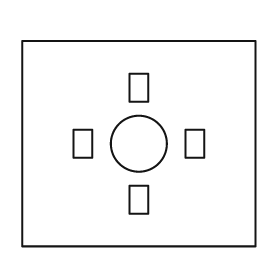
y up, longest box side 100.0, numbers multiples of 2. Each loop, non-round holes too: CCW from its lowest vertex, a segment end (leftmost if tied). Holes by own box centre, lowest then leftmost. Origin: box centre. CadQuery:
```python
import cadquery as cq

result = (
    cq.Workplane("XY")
    .moveTo(-50.0, -44.0)
    .lineTo(50.0, -44.0)
    .lineTo(50.0, 44.0)
    .lineTo(-50.0, 44.0)
    .close()
    .moveTo(-4.0, -30.0)
    .lineTo(4.0, -30.0)
    .lineTo(4.0, -18.0)
    .lineTo(-4.0, -18.0)
    .close()
    .moveTo(-28.0, -6.0)
    .lineTo(-20.0, -6.0)
    .lineTo(-20.0, 6.0)
    .lineTo(-28.0, 6.0)
    .close()
    .moveTo(0.0, 0.0)
    .circle(12.0)
    .moveTo(20.0, -6.0)
    .lineTo(28.0, -6.0)
    .lineTo(28.0, 6.0)
    .lineTo(20.0, 6.0)
    .close()
    .moveTo(-4.0, 18.0)
    .lineTo(4.0, 18.0)
    .lineTo(4.0, 30.0)
    .lineTo(-4.0, 30.0)
    .close()
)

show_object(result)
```